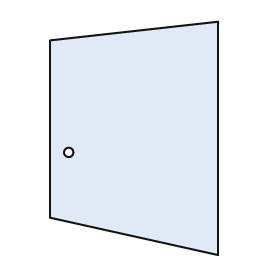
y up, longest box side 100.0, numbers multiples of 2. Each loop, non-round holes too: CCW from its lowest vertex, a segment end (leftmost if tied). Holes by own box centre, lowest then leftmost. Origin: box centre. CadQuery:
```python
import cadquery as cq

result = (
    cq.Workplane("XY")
    .moveTo(36.0, -50.0)
    .lineTo(36.0, 50.0)
    .lineTo(-36.0, 42.0)
    .lineTo(-36.0, -34.0)
    .close()
    .moveTo(-28.0, -6.0)
    .circle(2.0)
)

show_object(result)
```